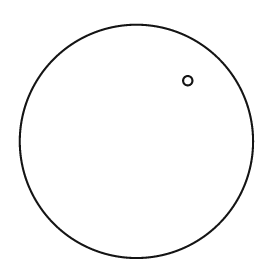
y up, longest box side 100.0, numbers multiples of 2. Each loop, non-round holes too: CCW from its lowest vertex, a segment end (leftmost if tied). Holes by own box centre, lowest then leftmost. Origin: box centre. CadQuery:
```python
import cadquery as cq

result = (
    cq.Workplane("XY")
    .moveTo(0.0, 0.0)
    .circle(50.0)
    .moveTo(22.0, 26.0)
    .circle(2.0)
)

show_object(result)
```